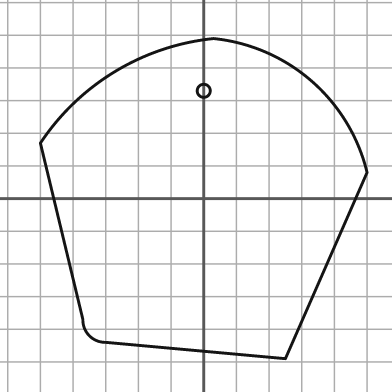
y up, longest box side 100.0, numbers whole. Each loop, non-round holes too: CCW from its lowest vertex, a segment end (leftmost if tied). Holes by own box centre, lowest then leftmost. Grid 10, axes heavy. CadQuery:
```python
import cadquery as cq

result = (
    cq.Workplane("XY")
    .moveTo(25.0, -49.0)
    .lineTo(50.0, 8.0)
    .threePointArc((33.0, 36.0), (3.0, 49.0))
    .threePointArc((-27.0, 39.0), (-50.0, 17.0))
    .lineTo(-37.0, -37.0)
    .threePointArc((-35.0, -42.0), (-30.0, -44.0))
    .close()
    .moveTo(0.0, 33.0)
    .circle(2.0)
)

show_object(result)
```